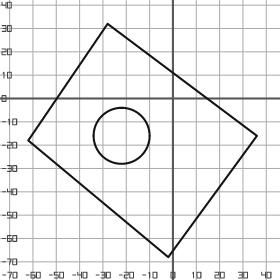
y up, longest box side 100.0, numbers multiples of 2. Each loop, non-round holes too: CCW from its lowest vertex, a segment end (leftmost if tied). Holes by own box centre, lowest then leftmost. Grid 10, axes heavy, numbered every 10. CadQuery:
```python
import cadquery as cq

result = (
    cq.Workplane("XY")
    .moveTo(-2.0, -68.0)
    .lineTo(36.0, -16.0)
    .lineTo(-28.0, 32.0)
    .lineTo(-62.0, -18.0)
    .close()
    .moveTo(-22.0, -16.0)
    .circle(12.0)
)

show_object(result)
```